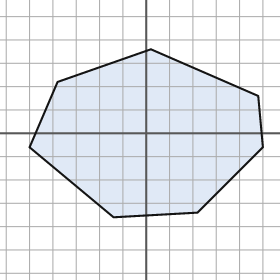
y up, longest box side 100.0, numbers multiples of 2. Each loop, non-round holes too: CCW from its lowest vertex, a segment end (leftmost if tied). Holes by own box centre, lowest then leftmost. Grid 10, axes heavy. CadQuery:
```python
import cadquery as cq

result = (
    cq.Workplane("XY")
    .moveTo(-14.0, -36.0)
    .lineTo(22.0, -34.0)
    .lineTo(50.0, -6.0)
    .lineTo(48.0, 16.0)
    .lineTo(2.0, 36.0)
    .lineTo(-38.0, 22.0)
    .lineTo(-50.0, -6.0)
    .close()
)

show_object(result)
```